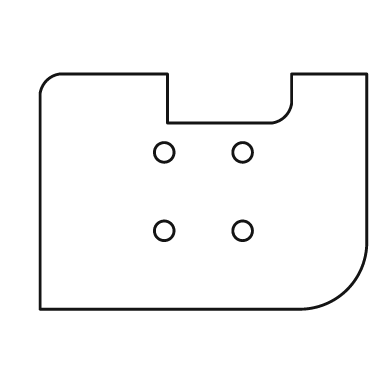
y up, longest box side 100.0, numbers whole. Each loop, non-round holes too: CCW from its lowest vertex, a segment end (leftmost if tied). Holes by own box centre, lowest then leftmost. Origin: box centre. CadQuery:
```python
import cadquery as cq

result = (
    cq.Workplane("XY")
    .moveTo(-50.0, -36.0)
    .lineTo(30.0, -36.0)
    .threePointArc((44.0, -30.0), (50.0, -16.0))
    .lineTo(50.0, 36.0)
    .lineTo(27.0, 36.0)
    .lineTo(27.0, 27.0)
    .threePointArc((25.0, 23.0), (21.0, 21.0))
    .lineTo(-11.0, 21.0)
    .lineTo(-11.0, 36.0)
    .lineTo(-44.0, 36.0)
    .threePointArc((-48.0, 34.0), (-50.0, 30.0))
    .close()
    .moveTo(-12.0, -12.0)
    .circle(3.0)
    .moveTo(12.0, -12.0)
    .circle(3.0)
    .moveTo(-12.0, 12.0)
    .circle(3.0)
    .moveTo(12.0, 12.0)
    .circle(3.0)
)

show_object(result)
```